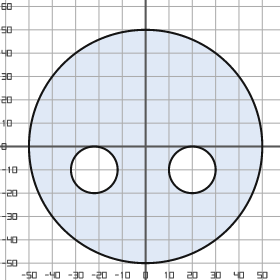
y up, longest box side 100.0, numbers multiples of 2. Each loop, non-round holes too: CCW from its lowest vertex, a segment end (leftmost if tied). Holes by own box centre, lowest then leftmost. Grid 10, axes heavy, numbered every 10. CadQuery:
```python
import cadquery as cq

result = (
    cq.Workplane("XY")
    .moveTo(0.0, 0.0)
    .circle(50.0)
    .moveTo(-22.0, -10.0)
    .circle(10.0)
    .moveTo(20.0, -10.0)
    .circle(10.0)
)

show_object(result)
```